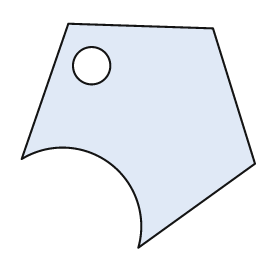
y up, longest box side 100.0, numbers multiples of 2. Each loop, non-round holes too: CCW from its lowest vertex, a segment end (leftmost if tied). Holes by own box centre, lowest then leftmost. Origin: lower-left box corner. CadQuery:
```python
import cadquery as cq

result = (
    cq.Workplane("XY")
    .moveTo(50.0, 0.0)
    .lineTo(100.0, 36.0)
    .lineTo(82.0, 94.0)
    .lineTo(20.0, 96.0)
    .lineTo(0.0, 38.0)
    .threePointArc((38.0, 36.0), (50.0, 0.0))
    .close()
    .moveTo(30.0, 78.0)
    .circle(8.0)
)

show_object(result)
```